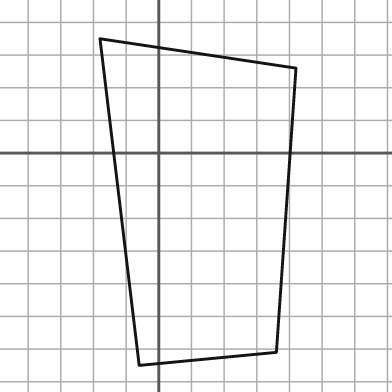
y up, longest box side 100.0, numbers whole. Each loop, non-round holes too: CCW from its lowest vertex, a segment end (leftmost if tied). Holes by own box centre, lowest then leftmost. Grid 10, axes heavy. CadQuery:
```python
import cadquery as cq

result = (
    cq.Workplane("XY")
    .moveTo(-6.0, -65.0)
    .lineTo(36.0, -61.0)
    .lineTo(42.0, 26.0)
    .lineTo(-18.0, 35.0)
    .close()
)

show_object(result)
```